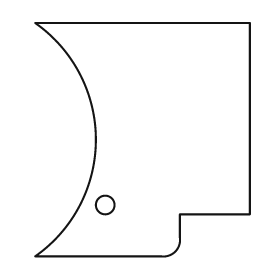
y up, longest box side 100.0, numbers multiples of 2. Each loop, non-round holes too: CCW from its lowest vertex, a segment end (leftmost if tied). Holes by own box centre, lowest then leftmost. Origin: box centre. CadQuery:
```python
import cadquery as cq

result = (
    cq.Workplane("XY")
    .moveTo(-46.0, -50.0)
    .lineTo(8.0, -50.0)
    .threePointArc((14.0, -48.0), (16.0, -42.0))
    .lineTo(16.0, -32.0)
    .lineTo(46.0, -32.0)
    .lineTo(46.0, 50.0)
    .lineTo(-46.0, 50.0)
    .threePointArc((-20.0, 0.0), (-46.0, -50.0))
    .close()
    .moveTo(-16.0, -28.0)
    .circle(4.0)
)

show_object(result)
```